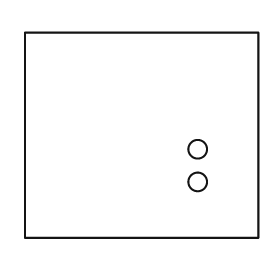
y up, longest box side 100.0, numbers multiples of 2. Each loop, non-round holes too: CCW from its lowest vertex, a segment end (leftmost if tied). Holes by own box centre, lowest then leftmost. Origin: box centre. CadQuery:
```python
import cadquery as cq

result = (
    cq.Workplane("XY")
    .moveTo(-50.0, -44.0)
    .lineTo(50.0, -44.0)
    .lineTo(50.0, 44.0)
    .lineTo(-50.0, 44.0)
    .close()
    .moveTo(24.0, -20.0)
    .circle(4.0)
    .moveTo(24.0, -6.0)
    .circle(4.0)
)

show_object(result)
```